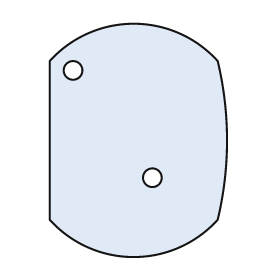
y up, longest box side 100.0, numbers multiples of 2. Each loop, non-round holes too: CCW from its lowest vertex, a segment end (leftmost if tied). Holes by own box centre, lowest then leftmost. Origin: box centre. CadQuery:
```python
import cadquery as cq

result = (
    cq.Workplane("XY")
    .moveTo(-38.0, -34.0)
    .threePointArc((-2.0, -50.0), (34.0, -34.0))
    .threePointArc((38.0, 0.0), (34.0, 34.0))
    .threePointArc((-2.0, 50.0), (-38.0, 34.0))
    .close()
    .moveTo(6.0, -16.0)
    .circle(4.0)
    .moveTo(-28.0, 30.0)
    .circle(4.0)
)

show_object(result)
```